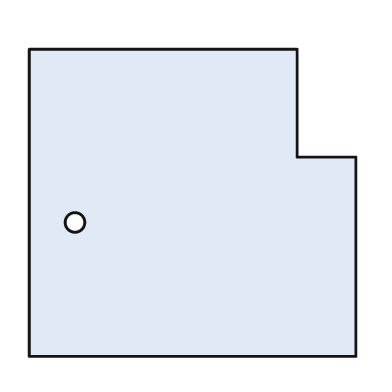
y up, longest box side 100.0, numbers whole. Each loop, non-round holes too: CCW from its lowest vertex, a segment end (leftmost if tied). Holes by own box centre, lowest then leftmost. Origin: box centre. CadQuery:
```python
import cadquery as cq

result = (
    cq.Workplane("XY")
    .moveTo(-50.0, -47.0)
    .lineTo(50.0, -47.0)
    .lineTo(50.0, 14.0)
    .lineTo(32.0, 14.0)
    .lineTo(32.0, 47.0)
    .lineTo(-50.0, 47.0)
    .close()
    .moveTo(-36.0, -6.0)
    .circle(3.0)
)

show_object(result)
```